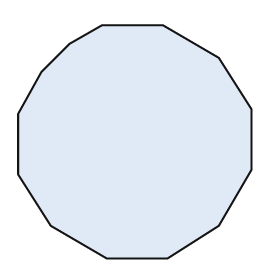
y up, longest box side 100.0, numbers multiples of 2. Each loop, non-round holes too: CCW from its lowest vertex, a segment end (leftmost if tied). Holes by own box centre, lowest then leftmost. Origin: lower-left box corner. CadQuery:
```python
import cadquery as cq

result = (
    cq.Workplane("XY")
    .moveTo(38.0, 0.0)
    .lineTo(64.0, 0.0)
    .lineTo(86.0, 14.0)
    .lineTo(100.0, 38.0)
    .lineTo(100.0, 64.0)
    .lineTo(86.0, 86.0)
    .lineTo(62.0, 100.0)
    .lineTo(36.0, 100.0)
    .lineTo(22.0, 92.0)
    .lineTo(10.0, 80.0)
    .lineTo(0.0, 62.0)
    .lineTo(0.0, 36.0)
    .lineTo(14.0, 14.0)
    .close()
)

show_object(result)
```